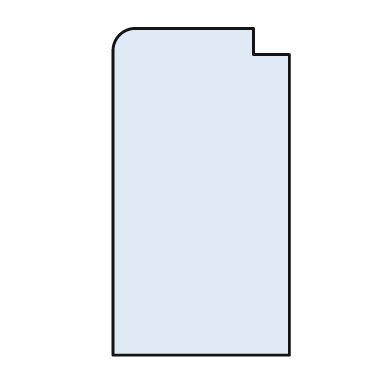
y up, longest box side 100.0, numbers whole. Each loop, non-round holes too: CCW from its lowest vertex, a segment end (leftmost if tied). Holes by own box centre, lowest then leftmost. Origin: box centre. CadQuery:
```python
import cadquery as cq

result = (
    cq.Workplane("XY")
    .moveTo(-27.0, -50.0)
    .lineTo(27.0, -50.0)
    .lineTo(27.0, 42.0)
    .lineTo(16.0, 42.0)
    .lineTo(16.0, 50.0)
    .lineTo(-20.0, 50.0)
    .threePointArc((-25.0, 48.0), (-27.0, 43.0))
    .close()
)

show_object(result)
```